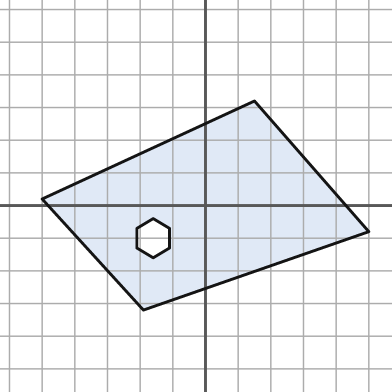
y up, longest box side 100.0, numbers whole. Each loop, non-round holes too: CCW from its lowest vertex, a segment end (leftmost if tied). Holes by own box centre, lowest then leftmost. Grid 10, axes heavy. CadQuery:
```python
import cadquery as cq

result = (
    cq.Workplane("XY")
    .moveTo(-19.0, -32.0)
    .lineTo(50.0, -8.0)
    .lineTo(15.0, 32.0)
    .lineTo(-50.0, 2.0)
    .close()
    .moveTo(-16.0, -16.0)
    .lineTo(-11.0, -13.0)
    .lineTo(-11.0, -7.0)
    .lineTo(-16.0, -4.0)
    .lineTo(-21.0, -7.0)
    .lineTo(-21.0, -13.0)
    .close()
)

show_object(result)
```